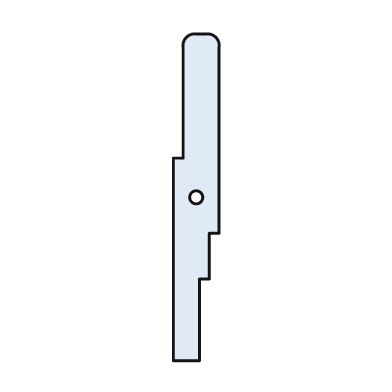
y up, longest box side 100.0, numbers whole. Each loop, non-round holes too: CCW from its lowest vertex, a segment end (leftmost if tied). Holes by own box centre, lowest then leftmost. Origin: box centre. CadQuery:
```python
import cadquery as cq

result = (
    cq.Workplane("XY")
    .moveTo(-7.0, -50.0)
    .lineTo(1.0, -50.0)
    .lineTo(1.0, -25.0)
    .lineTo(4.0, -25.0)
    .lineTo(4.0, -11.0)
    .lineTo(7.0, -11.0)
    .lineTo(7.0, 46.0)
    .threePointArc((6.0, 49.0), (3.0, 50.0))
    .lineTo(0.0, 50.0)
    .threePointArc((-3.0, 49.0), (-4.0, 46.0))
    .lineTo(-4.0, 12.0)
    .lineTo(-7.0, 12.0)
    .close()
    .moveTo(0.0, 0.0)
    .circle(2.0)
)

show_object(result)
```